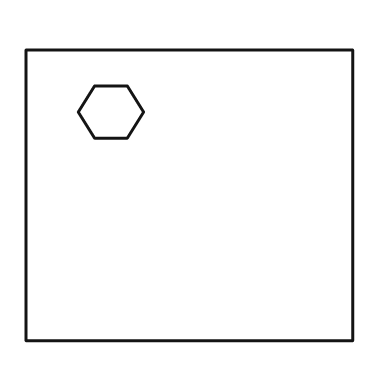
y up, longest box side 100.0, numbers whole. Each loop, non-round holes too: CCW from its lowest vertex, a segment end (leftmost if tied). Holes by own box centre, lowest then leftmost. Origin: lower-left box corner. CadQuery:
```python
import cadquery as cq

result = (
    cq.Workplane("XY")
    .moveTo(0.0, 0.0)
    .lineTo(100.0, 0.0)
    .lineTo(100.0, 89.0)
    .lineTo(0.0, 89.0)
    .close()
    .moveTo(21.0, 62.0)
    .lineTo(31.0, 62.0)
    .lineTo(36.0, 70.0)
    .lineTo(31.0, 78.0)
    .lineTo(21.0, 78.0)
    .lineTo(16.0, 70.0)
    .close()
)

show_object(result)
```